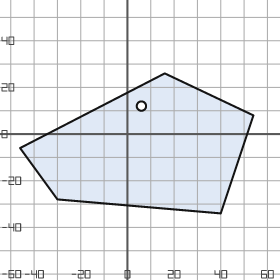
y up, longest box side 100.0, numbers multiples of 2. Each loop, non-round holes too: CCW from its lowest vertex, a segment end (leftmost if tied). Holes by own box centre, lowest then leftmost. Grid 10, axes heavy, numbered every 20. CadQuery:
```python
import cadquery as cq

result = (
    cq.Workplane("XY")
    .moveTo(40.0, -34.0)
    .lineTo(54.0, 8.0)
    .lineTo(16.0, 26.0)
    .lineTo(-46.0, -6.0)
    .lineTo(-30.0, -28.0)
    .close()
    .moveTo(6.0, 12.0)
    .circle(2.0)
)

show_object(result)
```